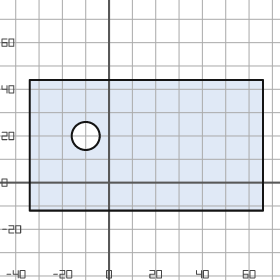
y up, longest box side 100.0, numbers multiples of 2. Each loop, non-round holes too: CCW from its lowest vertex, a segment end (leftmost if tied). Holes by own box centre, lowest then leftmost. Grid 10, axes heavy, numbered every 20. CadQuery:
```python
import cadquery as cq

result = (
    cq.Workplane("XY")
    .moveTo(-34.0, -12.0)
    .lineTo(66.0, -12.0)
    .lineTo(66.0, 44.0)
    .lineTo(-34.0, 44.0)
    .close()
    .moveTo(-10.0, 20.0)
    .circle(6.0)
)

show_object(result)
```